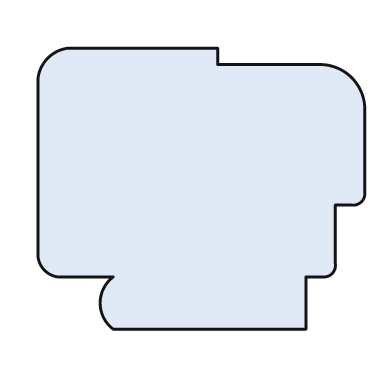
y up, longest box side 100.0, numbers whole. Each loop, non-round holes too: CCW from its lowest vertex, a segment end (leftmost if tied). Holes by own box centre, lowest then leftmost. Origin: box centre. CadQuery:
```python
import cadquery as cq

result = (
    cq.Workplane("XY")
    .moveTo(-27.0, -43.0)
    .lineTo(32.0, -43.0)
    .lineTo(32.0, -27.0)
    .lineTo(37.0, -27.0)
    .threePointArc((40.0, -26.0), (41.0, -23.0))
    .lineTo(41.0, -5.0)
    .lineTo(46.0, -5.0)
    .threePointArc((49.0, -4.0), (50.0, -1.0))
    .lineTo(50.0, 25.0)
    .threePointArc((46.0, 34.0), (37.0, 38.0))
    .lineTo(5.0, 38.0)
    .lineTo(5.0, 43.0)
    .lineTo(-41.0, 43.0)
    .threePointArc((-47.0, 40.0), (-50.0, 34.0))
    .lineTo(-50.0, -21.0)
    .threePointArc((-48.0, -25.0), (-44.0, -27.0))
    .lineTo(-27.0, -27.0)
    .threePointArc((-31.0, -35.0), (-27.0, -43.0))
    .close()
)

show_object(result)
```